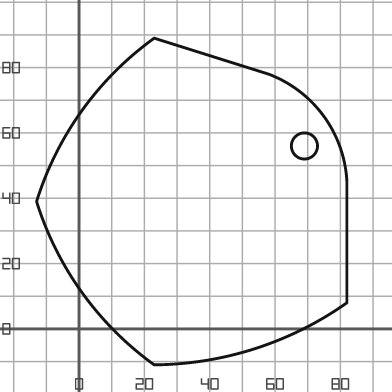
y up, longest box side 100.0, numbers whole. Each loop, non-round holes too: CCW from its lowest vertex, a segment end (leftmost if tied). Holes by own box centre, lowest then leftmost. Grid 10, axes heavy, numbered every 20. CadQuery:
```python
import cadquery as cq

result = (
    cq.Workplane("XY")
    .moveTo(23.0, -11.0)
    .threePointArc((54.0, -6.0), (82.0, 8.0))
    .lineTo(82.0, 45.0)
    .threePointArc((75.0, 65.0), (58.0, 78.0))
    .lineTo(23.0, 89.0)
    .threePointArc((1.0, 67.0), (-13.0, 39.0))
    .threePointArc((1.0, 11.0), (23.0, -11.0))
    .close()
    .moveTo(69.0, 56.0)
    .circle(4.0)
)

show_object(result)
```